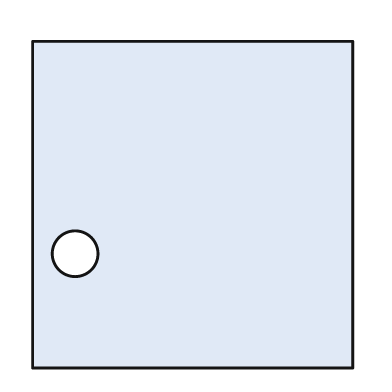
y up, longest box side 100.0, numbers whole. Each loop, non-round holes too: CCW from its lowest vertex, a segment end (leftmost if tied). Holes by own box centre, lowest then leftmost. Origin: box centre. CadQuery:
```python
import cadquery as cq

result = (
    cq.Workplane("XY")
    .moveTo(-49.0, -50.0)
    .lineTo(49.0, -50.0)
    .lineTo(49.0, 50.0)
    .lineTo(-49.0, 50.0)
    .close()
    .moveTo(-36.0, -15.0)
    .circle(7.0)
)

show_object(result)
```